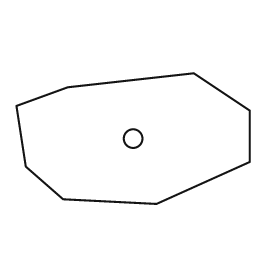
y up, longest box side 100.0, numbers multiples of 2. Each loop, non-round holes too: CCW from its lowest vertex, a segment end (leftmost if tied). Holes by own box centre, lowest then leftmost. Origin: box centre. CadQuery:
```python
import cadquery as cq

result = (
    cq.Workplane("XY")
    .moveTo(10.0, -28.0)
    .lineTo(50.0, -10.0)
    .lineTo(50.0, 12.0)
    .lineTo(26.0, 28.0)
    .lineTo(-28.0, 22.0)
    .lineTo(-50.0, 14.0)
    .lineTo(-46.0, -12.0)
    .lineTo(-30.0, -26.0)
    .close()
    .moveTo(0.0, 0.0)
    .circle(4.0)
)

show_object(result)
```